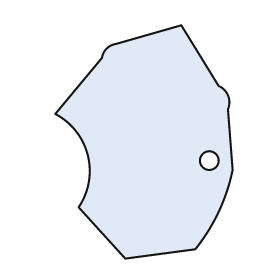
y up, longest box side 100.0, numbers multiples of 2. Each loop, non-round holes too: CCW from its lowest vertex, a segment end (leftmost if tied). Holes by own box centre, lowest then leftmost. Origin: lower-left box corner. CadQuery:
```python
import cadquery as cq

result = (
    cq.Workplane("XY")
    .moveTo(30.0, 0.0)
    .lineTo(60.0, 4.0)
    .threePointArc((70.0, 20.0), (76.0, 38.0))
    .lineTo(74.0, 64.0)
    .threePointArc((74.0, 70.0), (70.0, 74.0))
    .lineTo(54.0, 100.0)
    .lineTo(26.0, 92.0)
    .threePointArc((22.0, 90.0), (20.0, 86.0))
    .lineTo(0.0, 62.0)
    .threePointArc((14.0, 44.0), (10.0, 22.0))
    .close()
    .moveTo(66.0, 42.0)
    .circle(4.0)
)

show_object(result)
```